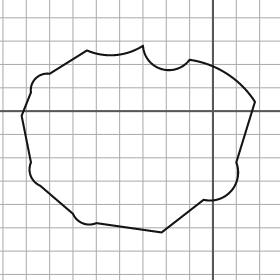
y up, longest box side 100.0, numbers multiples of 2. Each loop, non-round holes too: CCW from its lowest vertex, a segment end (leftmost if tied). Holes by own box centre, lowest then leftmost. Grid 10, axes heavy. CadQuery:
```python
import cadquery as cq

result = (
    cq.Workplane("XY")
    .moveTo(-22.0, -52.0)
    .lineTo(-4.0, -38.0)
    .threePointArc((8.0, -34.0), (10.0, -22.0))
    .lineTo(18.0, 4.0)
    .threePointArc((6.0, 16.0), (-10.0, 22.0))
    .threePointArc((-22.0, 18.0), (-30.0, 28.0))
    .threePointArc((-42.0, 24.0), (-54.0, 26.0))
    .lineTo(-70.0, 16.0)
    .threePointArc((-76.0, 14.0), (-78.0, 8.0))
    .lineTo(-82.0, -2.0)
    .lineTo(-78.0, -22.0)
    .threePointArc((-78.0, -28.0), (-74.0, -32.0))
    .lineTo(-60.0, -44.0)
    .threePointArc((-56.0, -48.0), (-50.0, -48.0))
    .close()
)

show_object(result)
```